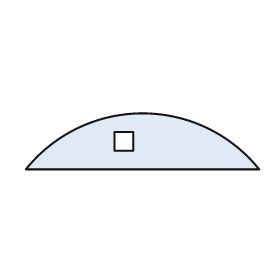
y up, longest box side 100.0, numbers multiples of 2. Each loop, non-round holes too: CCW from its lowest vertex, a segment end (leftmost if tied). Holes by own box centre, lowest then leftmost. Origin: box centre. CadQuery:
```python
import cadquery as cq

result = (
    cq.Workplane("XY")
    .moveTo(-50.0, -12.0)
    .lineTo(50.0, -12.0)
    .threePointArc((0.0, 12.0), (-50.0, -12.0))
    .close()
    .moveTo(-12.0, -4.0)
    .lineTo(-4.0, -4.0)
    .lineTo(-4.0, 4.0)
    .lineTo(-12.0, 4.0)
    .close()
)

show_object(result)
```